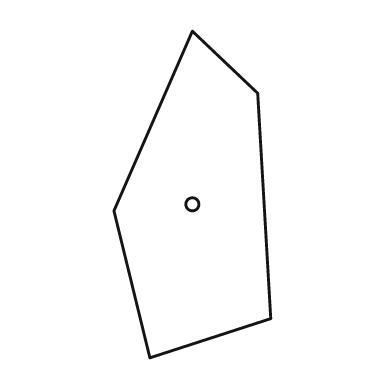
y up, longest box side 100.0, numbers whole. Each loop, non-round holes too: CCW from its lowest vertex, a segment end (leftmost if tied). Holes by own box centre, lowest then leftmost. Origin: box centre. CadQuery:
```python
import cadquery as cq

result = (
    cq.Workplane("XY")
    .moveTo(-13.0, -50.0)
    .lineTo(24.0, -38.0)
    .lineTo(20.0, 31.0)
    .lineTo(0.0, 50.0)
    .lineTo(-24.0, -5.0)
    .close()
    .moveTo(0.0, -3.0)
    .circle(2.0)
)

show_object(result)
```